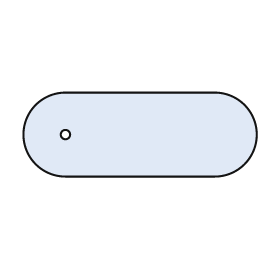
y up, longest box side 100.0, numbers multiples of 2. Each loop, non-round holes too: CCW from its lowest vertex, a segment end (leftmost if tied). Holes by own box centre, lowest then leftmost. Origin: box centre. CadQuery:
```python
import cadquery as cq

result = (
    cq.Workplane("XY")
    .moveTo(-32.0, -18.0)
    .lineTo(32.0, -18.0)
    .threePointArc((50.0, 0.0), (32.0, 18.0))
    .lineTo(-32.0, 18.0)
    .threePointArc((-50.0, 0.0), (-32.0, -18.0))
    .close()
    .moveTo(-32.0, 0.0)
    .circle(2.0)
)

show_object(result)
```